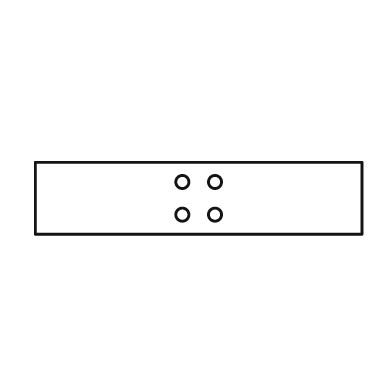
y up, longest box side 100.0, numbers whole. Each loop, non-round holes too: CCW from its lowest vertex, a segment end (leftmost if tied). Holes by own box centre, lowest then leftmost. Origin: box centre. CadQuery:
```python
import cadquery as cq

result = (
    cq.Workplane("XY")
    .moveTo(-50.0, -11.0)
    .lineTo(50.0, -11.0)
    .lineTo(50.0, 11.0)
    .lineTo(-50.0, 11.0)
    .close()
    .moveTo(-5.0, -5.0)
    .circle(2.0)
    .moveTo(5.0, -5.0)
    .circle(2.0)
    .moveTo(-5.0, 5.0)
    .circle(2.0)
    .moveTo(5.0, 5.0)
    .circle(2.0)
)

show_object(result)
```